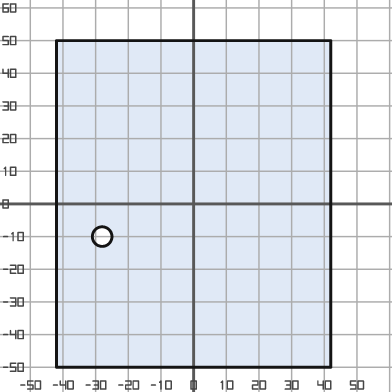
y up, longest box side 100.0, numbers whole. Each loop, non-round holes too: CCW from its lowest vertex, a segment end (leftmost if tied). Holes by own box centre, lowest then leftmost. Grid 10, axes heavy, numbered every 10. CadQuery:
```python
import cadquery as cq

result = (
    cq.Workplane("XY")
    .moveTo(-42.0, -50.0)
    .lineTo(42.0, -50.0)
    .lineTo(42.0, 50.0)
    .lineTo(-42.0, 50.0)
    .close()
    .moveTo(-28.0, -10.0)
    .circle(3.0)
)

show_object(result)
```